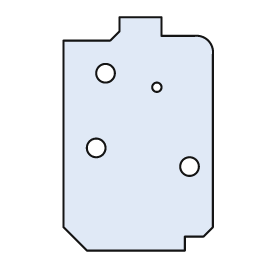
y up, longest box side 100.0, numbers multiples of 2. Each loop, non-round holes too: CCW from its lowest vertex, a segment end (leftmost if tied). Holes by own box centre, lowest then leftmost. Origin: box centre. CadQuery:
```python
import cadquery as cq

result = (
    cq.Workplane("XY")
    .moveTo(-22.0, -50.0)
    .lineTo(20.0, -50.0)
    .lineTo(20.0, -44.0)
    .lineTo(28.0, -44.0)
    .lineTo(32.0, -40.0)
    .lineTo(32.0, 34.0)
    .threePointArc((30.0, 40.0), (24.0, 42.0))
    .lineTo(10.0, 42.0)
    .lineTo(10.0, 50.0)
    .lineTo(-8.0, 50.0)
    .lineTo(-8.0, 44.0)
    .lineTo(-12.0, 40.0)
    .lineTo(-32.0, 40.0)
    .lineTo(-32.0, -40.0)
    .close()
    .moveTo(22.0, -14.0)
    .circle(4.0)
    .moveTo(-18.0, -6.0)
    .circle(4.0)
    .moveTo(8.0, 20.0)
    .circle(2.0)
    .moveTo(-14.0, 26.0)
    .circle(4.0)
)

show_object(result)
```